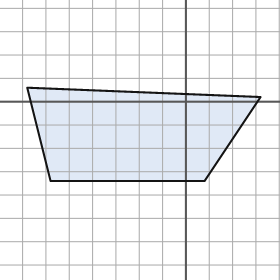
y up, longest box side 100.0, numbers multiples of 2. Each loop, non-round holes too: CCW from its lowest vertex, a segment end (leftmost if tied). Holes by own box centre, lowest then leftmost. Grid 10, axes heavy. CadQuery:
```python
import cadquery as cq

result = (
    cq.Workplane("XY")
    .moveTo(-58.0, -34.0)
    .lineTo(8.0, -34.0)
    .lineTo(32.0, 2.0)
    .lineTo(-68.0, 6.0)
    .close()
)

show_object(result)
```